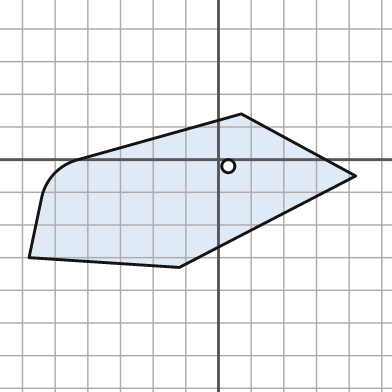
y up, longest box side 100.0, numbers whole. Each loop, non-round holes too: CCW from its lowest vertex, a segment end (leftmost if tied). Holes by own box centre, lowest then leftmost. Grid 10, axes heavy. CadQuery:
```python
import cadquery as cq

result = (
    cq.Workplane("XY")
    .moveTo(-12.0, -33.0)
    .lineTo(42.0, -5.0)
    .lineTo(7.0, 14.0)
    .lineTo(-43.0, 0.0)
    .threePointArc((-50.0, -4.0), (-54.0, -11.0))
    .lineTo(-58.0, -30.0)
    .close()
    .moveTo(3.0, -2.0)
    .circle(2.0)
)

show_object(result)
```